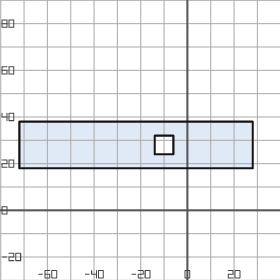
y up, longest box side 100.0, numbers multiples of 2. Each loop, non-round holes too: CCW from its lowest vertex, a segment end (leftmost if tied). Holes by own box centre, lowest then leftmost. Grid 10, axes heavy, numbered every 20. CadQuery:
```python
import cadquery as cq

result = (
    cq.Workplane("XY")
    .moveTo(-72.0, 18.0)
    .lineTo(28.0, 18.0)
    .lineTo(28.0, 38.0)
    .lineTo(-72.0, 38.0)
    .close()
    .moveTo(-14.0, 24.0)
    .lineTo(-6.0, 24.0)
    .lineTo(-6.0, 32.0)
    .lineTo(-14.0, 32.0)
    .close()
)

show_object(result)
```